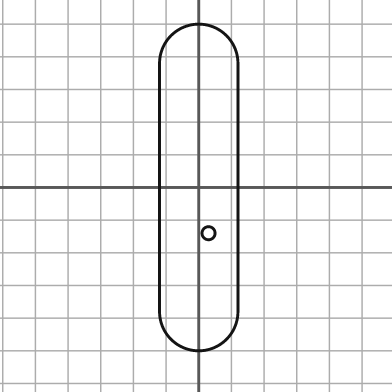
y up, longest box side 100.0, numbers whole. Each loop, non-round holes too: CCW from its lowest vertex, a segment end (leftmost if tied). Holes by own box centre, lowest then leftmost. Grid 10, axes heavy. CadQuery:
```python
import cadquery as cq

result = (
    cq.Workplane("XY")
    .moveTo(-12.0, -38.0)
    .threePointArc((0.0, -50.0), (12.0, -38.0))
    .lineTo(12.0, 38.0)
    .threePointArc((0.0, 50.0), (-12.0, 38.0))
    .close()
    .moveTo(3.0, -14.0)
    .circle(2.0)
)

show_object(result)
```